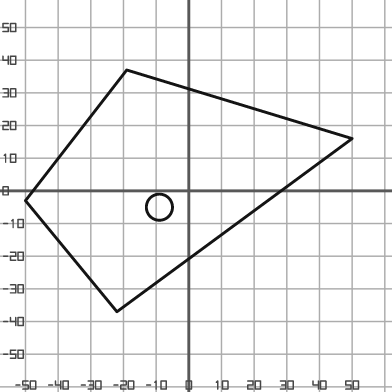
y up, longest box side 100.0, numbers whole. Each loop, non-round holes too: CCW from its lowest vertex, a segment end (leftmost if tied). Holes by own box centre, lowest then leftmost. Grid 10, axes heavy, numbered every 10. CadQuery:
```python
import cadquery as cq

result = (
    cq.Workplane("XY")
    .moveTo(-22.0, -37.0)
    .lineTo(50.0, 16.0)
    .lineTo(-19.0, 37.0)
    .lineTo(-50.0, -3.0)
    .close()
    .moveTo(-9.0, -5.0)
    .circle(4.0)
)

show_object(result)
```